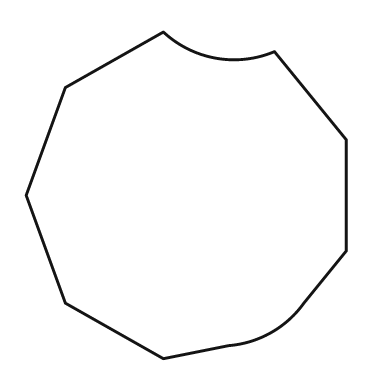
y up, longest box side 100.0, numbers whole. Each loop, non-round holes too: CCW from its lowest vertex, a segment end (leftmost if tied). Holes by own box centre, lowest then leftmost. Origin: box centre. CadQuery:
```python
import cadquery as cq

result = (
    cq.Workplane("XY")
    .moveTo(-7.0, -50.0)
    .lineTo(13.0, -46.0)
    .threePointArc((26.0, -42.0), (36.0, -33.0))
    .lineTo(49.0, -17.0)
    .lineTo(49.0, 17.0)
    .lineTo(27.0, 44.0)
    .threePointArc((9.0, 42.0), (-7.0, 50.0))
    .lineTo(-37.0, 33.0)
    .lineTo(-49.0, 0.0)
    .lineTo(-37.0, -33.0)
    .close()
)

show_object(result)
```